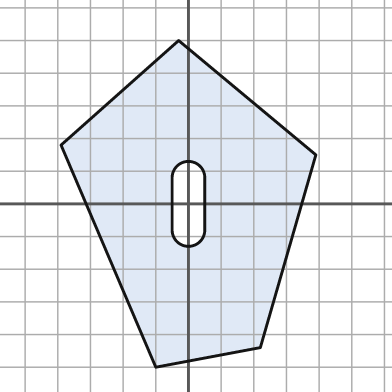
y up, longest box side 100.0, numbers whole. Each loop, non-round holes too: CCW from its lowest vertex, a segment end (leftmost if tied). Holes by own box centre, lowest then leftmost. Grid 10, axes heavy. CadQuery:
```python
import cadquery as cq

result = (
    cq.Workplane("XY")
    .moveTo(-10.0, -50.0)
    .lineTo(22.0, -44.0)
    .lineTo(39.0, 15.0)
    .lineTo(-3.0, 50.0)
    .lineTo(-39.0, 18.0)
    .close()
    .moveTo(-5.0, -8.0)
    .threePointArc((0.0, -13.0), (5.0, -8.0))
    .lineTo(5.0, 8.0)
    .threePointArc((0.0, 13.0), (-5.0, 8.0))
    .close()
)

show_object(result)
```